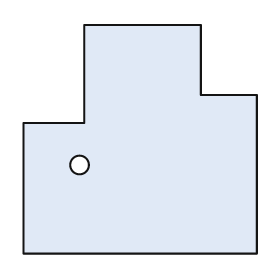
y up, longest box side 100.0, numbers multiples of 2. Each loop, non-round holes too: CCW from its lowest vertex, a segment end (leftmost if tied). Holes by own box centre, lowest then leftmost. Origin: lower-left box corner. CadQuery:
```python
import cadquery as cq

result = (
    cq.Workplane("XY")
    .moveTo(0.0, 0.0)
    .lineTo(100.0, 0.0)
    .lineTo(100.0, 68.0)
    .lineTo(76.0, 68.0)
    .lineTo(76.0, 98.0)
    .lineTo(26.0, 98.0)
    .lineTo(26.0, 56.0)
    .lineTo(0.0, 56.0)
    .close()
    .moveTo(24.0, 38.0)
    .circle(4.0)
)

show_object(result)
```